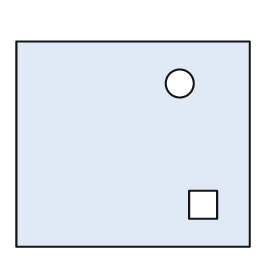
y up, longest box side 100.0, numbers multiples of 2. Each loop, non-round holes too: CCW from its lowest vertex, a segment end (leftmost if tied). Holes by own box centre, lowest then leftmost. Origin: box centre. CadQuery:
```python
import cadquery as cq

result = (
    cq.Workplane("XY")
    .moveTo(-50.0, -44.0)
    .lineTo(50.0, -44.0)
    .lineTo(50.0, 44.0)
    .lineTo(-50.0, 44.0)
    .close()
    .moveTo(24.0, -32.0)
    .lineTo(36.0, -32.0)
    .lineTo(36.0, -20.0)
    .lineTo(24.0, -20.0)
    .close()
    .moveTo(20.0, 26.0)
    .circle(6.0)
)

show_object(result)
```